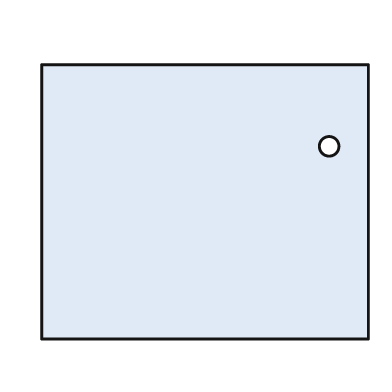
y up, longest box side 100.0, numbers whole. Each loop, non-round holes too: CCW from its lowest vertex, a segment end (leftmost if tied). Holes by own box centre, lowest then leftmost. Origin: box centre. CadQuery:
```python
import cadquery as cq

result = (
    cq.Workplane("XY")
    .moveTo(-50.0, -42.0)
    .lineTo(50.0, -42.0)
    .lineTo(50.0, 42.0)
    .lineTo(-50.0, 42.0)
    .close()
    .moveTo(38.0, 17.0)
    .circle(3.0)
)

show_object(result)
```